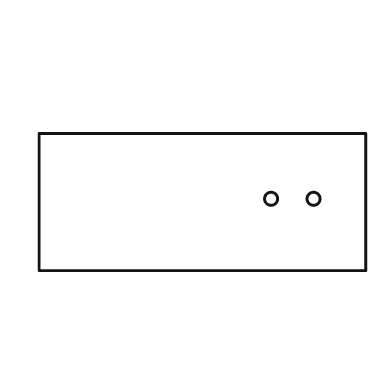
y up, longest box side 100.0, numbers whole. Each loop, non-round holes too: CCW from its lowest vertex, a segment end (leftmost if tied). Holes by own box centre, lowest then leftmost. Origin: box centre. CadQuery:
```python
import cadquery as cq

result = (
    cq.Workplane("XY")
    .moveTo(-50.0, -21.0)
    .lineTo(50.0, -21.0)
    .lineTo(50.0, 21.0)
    .lineTo(-50.0, 21.0)
    .close()
    .moveTo(21.0, 1.0)
    .circle(2.0)
    .moveTo(34.0, 1.0)
    .circle(2.0)
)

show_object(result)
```